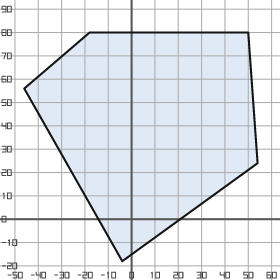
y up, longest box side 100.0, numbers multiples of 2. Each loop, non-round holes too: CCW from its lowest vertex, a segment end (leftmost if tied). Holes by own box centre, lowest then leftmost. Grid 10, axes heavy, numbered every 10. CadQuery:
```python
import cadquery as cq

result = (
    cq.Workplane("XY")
    .moveTo(-4.0, -18.0)
    .lineTo(54.0, 24.0)
    .lineTo(50.0, 80.0)
    .lineTo(-18.0, 80.0)
    .lineTo(-46.0, 56.0)
    .close()
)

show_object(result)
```